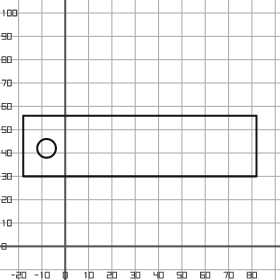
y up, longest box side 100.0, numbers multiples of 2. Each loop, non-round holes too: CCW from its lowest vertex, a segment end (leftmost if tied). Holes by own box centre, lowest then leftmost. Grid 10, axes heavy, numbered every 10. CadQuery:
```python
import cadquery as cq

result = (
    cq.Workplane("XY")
    .moveTo(-18.0, 30.0)
    .lineTo(82.0, 30.0)
    .lineTo(82.0, 56.0)
    .lineTo(-18.0, 56.0)
    .close()
    .moveTo(-8.0, 42.0)
    .circle(4.0)
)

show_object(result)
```